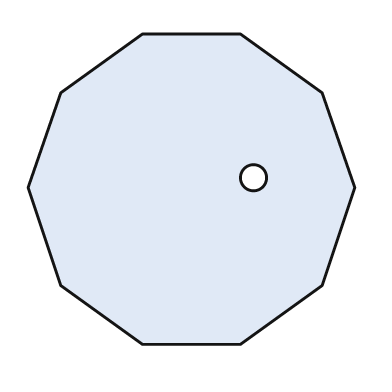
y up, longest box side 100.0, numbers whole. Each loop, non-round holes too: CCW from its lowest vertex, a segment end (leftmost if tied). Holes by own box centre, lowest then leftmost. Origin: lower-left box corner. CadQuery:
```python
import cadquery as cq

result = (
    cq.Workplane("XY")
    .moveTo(35.0, 0.0)
    .lineTo(65.0, 0.0)
    .lineTo(90.0, 18.0)
    .lineTo(100.0, 48.0)
    .lineTo(90.0, 77.0)
    .lineTo(65.0, 95.0)
    .lineTo(35.0, 95.0)
    .lineTo(10.0, 77.0)
    .lineTo(0.0, 48.0)
    .lineTo(10.0, 18.0)
    .close()
    .moveTo(69.0, 51.0)
    .circle(4.0)
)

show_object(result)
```